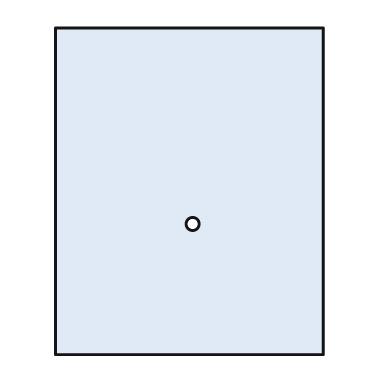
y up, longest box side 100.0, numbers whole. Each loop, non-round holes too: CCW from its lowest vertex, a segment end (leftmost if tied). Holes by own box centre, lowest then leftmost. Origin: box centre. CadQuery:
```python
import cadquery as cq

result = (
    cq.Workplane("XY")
    .moveTo(-41.0, -50.0)
    .lineTo(41.0, -50.0)
    .lineTo(41.0, 50.0)
    .lineTo(-41.0, 50.0)
    .close()
    .moveTo(1.0, -10.0)
    .circle(2.0)
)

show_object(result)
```